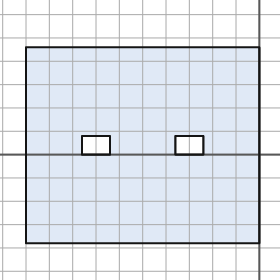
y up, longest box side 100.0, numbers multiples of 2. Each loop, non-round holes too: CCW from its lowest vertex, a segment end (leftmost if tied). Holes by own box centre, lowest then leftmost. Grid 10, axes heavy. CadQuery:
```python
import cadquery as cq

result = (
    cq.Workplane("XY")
    .moveTo(-100.0, -38.0)
    .lineTo(0.0, -38.0)
    .lineTo(0.0, 46.0)
    .lineTo(-100.0, 46.0)
    .close()
    .moveTo(-76.0, 0.0)
    .lineTo(-64.0, 0.0)
    .lineTo(-64.0, 8.0)
    .lineTo(-76.0, 8.0)
    .close()
    .moveTo(-36.0, 0.0)
    .lineTo(-24.0, 0.0)
    .lineTo(-24.0, 8.0)
    .lineTo(-36.0, 8.0)
    .close()
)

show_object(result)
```